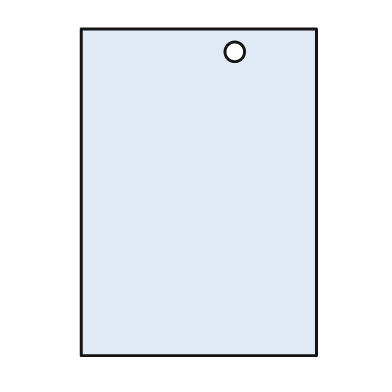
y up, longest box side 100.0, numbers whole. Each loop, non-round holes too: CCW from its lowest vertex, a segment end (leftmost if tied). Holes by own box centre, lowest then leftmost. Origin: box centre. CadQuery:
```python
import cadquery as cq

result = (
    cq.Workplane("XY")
    .moveTo(-36.0, -50.0)
    .lineTo(36.0, -50.0)
    .lineTo(36.0, 50.0)
    .lineTo(-36.0, 50.0)
    .close()
    .moveTo(11.0, 43.0)
    .circle(3.0)
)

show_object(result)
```